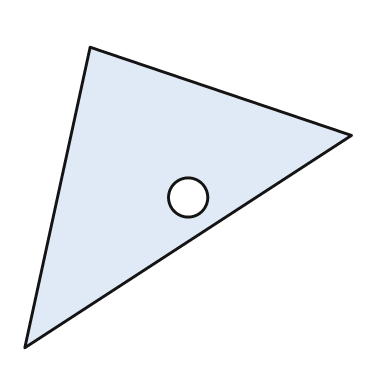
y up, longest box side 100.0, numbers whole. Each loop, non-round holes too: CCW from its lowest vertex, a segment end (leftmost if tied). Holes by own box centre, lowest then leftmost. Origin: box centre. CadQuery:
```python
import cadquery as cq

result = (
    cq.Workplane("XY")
    .moveTo(-50.0, -46.0)
    .lineTo(50.0, 19.0)
    .lineTo(-30.0, 46.0)
    .close()
    .moveTo(0.0, 0.0)
    .circle(6.0)
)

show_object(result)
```